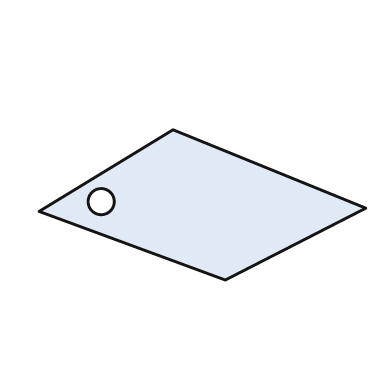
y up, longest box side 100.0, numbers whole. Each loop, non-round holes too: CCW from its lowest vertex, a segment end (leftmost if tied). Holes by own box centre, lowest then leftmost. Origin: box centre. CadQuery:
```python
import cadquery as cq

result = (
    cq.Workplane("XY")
    .moveTo(7.0, -23.0)
    .lineTo(50.0, -1.0)
    .lineTo(-9.0, 23.0)
    .lineTo(-50.0, -2.0)
    .close()
    .moveTo(-31.0, 1.0)
    .circle(4.0)
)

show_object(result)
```